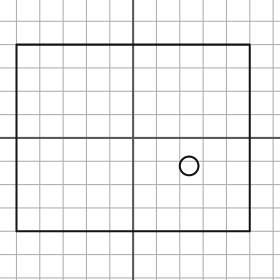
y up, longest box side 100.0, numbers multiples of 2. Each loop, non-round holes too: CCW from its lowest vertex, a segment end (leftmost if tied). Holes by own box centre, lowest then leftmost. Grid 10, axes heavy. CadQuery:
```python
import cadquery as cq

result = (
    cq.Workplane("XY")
    .moveTo(-50.0, -40.0)
    .lineTo(50.0, -40.0)
    .lineTo(50.0, 40.0)
    .lineTo(-50.0, 40.0)
    .close()
    .moveTo(24.0, -12.0)
    .circle(4.0)
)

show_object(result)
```